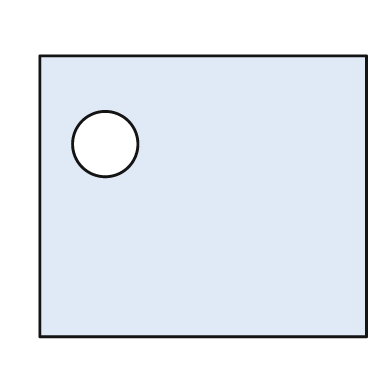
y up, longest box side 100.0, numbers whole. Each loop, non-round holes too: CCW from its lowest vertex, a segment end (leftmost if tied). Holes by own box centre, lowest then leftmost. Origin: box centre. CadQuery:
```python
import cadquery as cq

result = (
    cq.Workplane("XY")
    .moveTo(-50.0, -43.0)
    .lineTo(50.0, -43.0)
    .lineTo(50.0, 43.0)
    .lineTo(-50.0, 43.0)
    .close()
    .moveTo(-30.0, 16.0)
    .circle(10.0)
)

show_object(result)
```